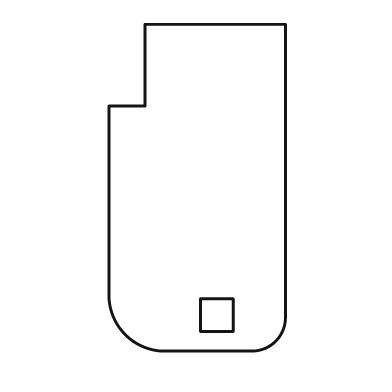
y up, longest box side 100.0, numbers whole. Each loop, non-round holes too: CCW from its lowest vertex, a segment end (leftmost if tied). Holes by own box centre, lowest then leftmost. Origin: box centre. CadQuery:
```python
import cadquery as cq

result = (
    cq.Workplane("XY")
    .moveTo(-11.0, -50.0)
    .lineTo(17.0, -50.0)
    .threePointArc((24.0, -47.0), (27.0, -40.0))
    .lineTo(27.0, 50.0)
    .lineTo(-16.0, 50.0)
    .lineTo(-16.0, 25.0)
    .lineTo(-27.0, 25.0)
    .lineTo(-27.0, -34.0)
    .threePointArc((-22.0, -45.0), (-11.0, -50.0))
    .close()
    .moveTo(1.0, -44.0)
    .lineTo(11.0, -44.0)
    .lineTo(11.0, -34.0)
    .lineTo(1.0, -34.0)
    .close()
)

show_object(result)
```